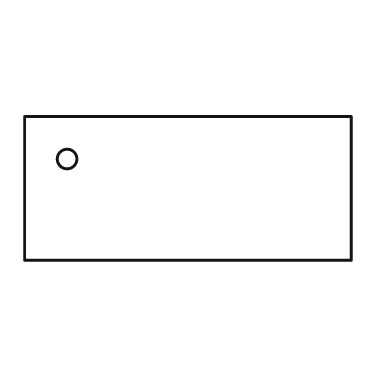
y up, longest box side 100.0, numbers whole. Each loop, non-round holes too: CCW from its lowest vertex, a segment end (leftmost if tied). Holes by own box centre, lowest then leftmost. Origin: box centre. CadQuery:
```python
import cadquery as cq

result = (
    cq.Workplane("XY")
    .moveTo(-50.0, -22.0)
    .lineTo(50.0, -22.0)
    .lineTo(50.0, 22.0)
    .lineTo(-50.0, 22.0)
    .close()
    .moveTo(-37.0, 9.0)
    .circle(3.0)
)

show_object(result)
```